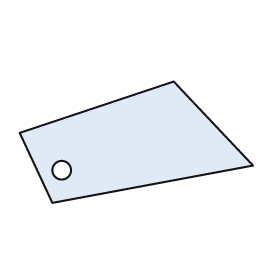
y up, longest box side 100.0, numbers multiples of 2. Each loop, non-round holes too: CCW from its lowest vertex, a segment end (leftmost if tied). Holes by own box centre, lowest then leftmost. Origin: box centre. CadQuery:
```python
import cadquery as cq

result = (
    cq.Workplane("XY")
    .moveTo(-36.0, -26.0)
    .lineTo(50.0, -10.0)
    .lineTo(16.0, 26.0)
    .lineTo(-50.0, 4.0)
    .close()
    .moveTo(-32.0, -12.0)
    .circle(4.0)
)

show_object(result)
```